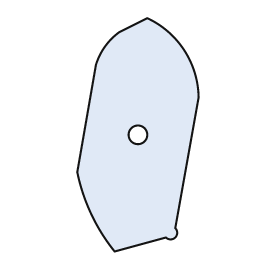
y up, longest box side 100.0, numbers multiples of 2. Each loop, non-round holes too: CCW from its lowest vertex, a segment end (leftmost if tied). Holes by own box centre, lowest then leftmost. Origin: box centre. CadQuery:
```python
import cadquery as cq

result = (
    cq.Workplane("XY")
    .moveTo(-10.0, -50.0)
    .lineTo(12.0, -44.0)
    .threePointArc((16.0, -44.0), (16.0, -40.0))
    .lineTo(26.0, 16.0)
    .threePointArc((20.0, 36.0), (4.0, 50.0))
    .lineTo(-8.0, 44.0)
    .threePointArc((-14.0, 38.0), (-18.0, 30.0))
    .lineTo(-26.0, -16.0)
    .threePointArc((-20.0, -34.0), (-10.0, -50.0))
    .close()
    .moveTo(0.0, 0.0)
    .circle(4.0)
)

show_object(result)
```